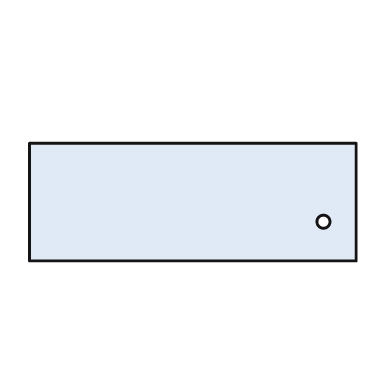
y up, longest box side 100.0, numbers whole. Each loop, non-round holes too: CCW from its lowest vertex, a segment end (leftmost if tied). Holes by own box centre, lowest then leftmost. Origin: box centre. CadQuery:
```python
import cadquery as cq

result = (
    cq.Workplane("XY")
    .moveTo(-50.0, -18.0)
    .lineTo(50.0, -18.0)
    .lineTo(50.0, 18.0)
    .lineTo(-50.0, 18.0)
    .close()
    .moveTo(40.0, -6.0)
    .circle(2.0)
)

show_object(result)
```